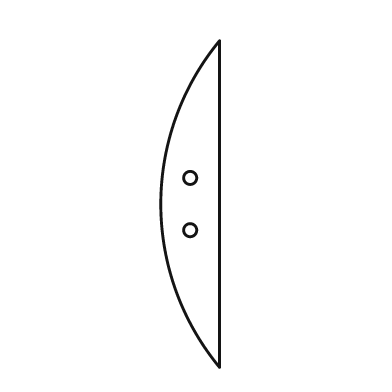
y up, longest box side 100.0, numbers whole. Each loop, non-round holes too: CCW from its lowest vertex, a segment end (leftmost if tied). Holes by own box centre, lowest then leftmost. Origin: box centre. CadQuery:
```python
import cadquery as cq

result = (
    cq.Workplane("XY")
    .moveTo(9.0, -50.0)
    .lineTo(9.0, 50.0)
    .threePointArc((-9.0, 0.0), (9.0, -50.0))
    .close()
    .moveTo(0.0, -8.0)
    .circle(2.0)
    .moveTo(0.0, 8.0)
    .circle(2.0)
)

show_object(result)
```